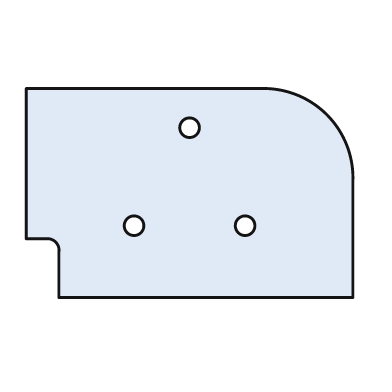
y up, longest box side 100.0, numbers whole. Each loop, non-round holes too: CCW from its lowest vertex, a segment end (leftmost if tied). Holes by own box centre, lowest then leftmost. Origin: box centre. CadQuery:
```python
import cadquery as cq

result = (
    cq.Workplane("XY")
    .moveTo(-40.0, -32.0)
    .lineTo(50.0, -32.0)
    .lineTo(50.0, 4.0)
    .threePointArc((42.0, 24.0), (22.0, 32.0))
    .lineTo(-50.0, 32.0)
    .lineTo(-50.0, -14.0)
    .lineTo(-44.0, -14.0)
    .threePointArc((-41.0, -15.0), (-40.0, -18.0))
    .close()
    .moveTo(-17.0, -10.0)
    .circle(3.0)
    .moveTo(17.0, -10.0)
    .circle(3.0)
    .moveTo(0.0, 20.0)
    .circle(3.0)
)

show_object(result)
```